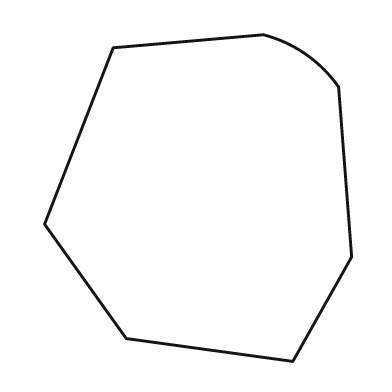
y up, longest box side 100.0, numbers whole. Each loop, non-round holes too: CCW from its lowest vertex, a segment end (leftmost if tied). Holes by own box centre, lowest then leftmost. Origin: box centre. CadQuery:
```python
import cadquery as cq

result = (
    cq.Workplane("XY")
    .moveTo(29.0, -50.0)
    .lineTo(47.0, -18.0)
    .lineTo(43.0, 34.0)
    .threePointArc((33.0, 44.0), (20.0, 50.0))
    .lineTo(-26.0, 46.0)
    .lineTo(-47.0, -8.0)
    .lineTo(-22.0, -43.0)
    .close()
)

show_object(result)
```